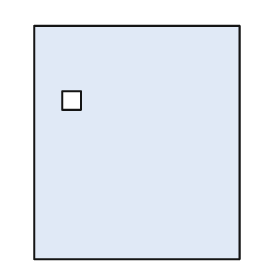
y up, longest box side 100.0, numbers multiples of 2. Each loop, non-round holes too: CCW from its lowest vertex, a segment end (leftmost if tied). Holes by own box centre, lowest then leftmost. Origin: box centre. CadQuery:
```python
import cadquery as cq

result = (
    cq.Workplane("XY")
    .moveTo(-44.0, -50.0)
    .lineTo(44.0, -50.0)
    .lineTo(44.0, 50.0)
    .lineTo(-44.0, 50.0)
    .close()
    .moveTo(-32.0, 14.0)
    .lineTo(-24.0, 14.0)
    .lineTo(-24.0, 22.0)
    .lineTo(-32.0, 22.0)
    .close()
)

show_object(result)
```